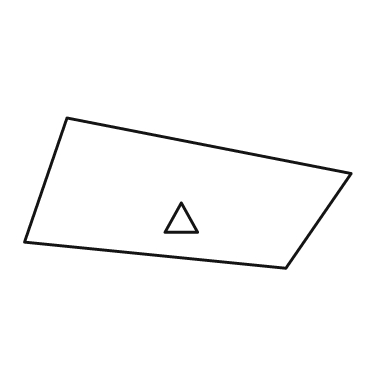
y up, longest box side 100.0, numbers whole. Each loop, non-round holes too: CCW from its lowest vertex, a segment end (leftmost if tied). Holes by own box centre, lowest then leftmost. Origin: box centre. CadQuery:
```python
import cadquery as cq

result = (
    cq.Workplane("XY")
    .moveTo(30.0, -23.0)
    .lineTo(50.0, 6.0)
    .lineTo(-37.0, 23.0)
    .lineTo(-50.0, -15.0)
    .close()
    .moveTo(-7.0, -12.0)
    .lineTo(3.0, -12.0)
    .lineTo(-2.0, -3.0)
    .close()
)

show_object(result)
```